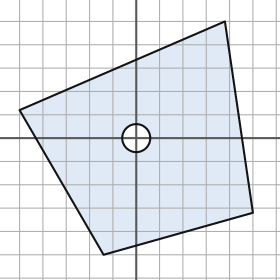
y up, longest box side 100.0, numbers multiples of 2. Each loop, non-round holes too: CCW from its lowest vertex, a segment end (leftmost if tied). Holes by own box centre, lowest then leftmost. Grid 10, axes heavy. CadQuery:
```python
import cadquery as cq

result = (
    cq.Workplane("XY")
    .moveTo(-14.0, -50.0)
    .lineTo(50.0, -32.0)
    .lineTo(38.0, 50.0)
    .lineTo(-50.0, 12.0)
    .close()
    .moveTo(0.0, 0.0)
    .circle(6.0)
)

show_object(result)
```